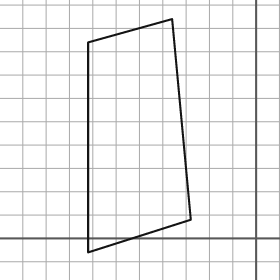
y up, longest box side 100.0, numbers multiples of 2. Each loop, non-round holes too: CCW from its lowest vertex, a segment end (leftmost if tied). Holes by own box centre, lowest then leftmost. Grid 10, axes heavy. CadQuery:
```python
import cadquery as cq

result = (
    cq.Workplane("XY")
    .moveTo(-72.0, -6.0)
    .lineTo(-28.0, 8.0)
    .lineTo(-36.0, 94.0)
    .lineTo(-72.0, 84.0)
    .close()
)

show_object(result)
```